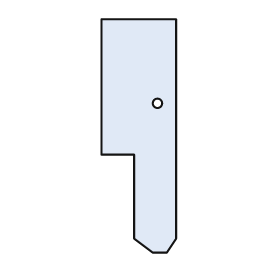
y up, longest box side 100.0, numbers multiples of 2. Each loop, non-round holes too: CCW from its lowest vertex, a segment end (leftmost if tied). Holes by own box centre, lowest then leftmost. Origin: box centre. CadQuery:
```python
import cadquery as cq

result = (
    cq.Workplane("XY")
    .moveTo(6.0, -50.0)
    .lineTo(12.0, -50.0)
    .lineTo(16.0, -44.0)
    .lineTo(16.0, 50.0)
    .lineTo(-16.0, 50.0)
    .lineTo(-16.0, -8.0)
    .lineTo(-2.0, -8.0)
    .lineTo(-2.0, -44.0)
    .close()
    .moveTo(8.0, 14.0)
    .circle(2.0)
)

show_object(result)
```